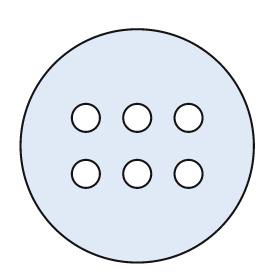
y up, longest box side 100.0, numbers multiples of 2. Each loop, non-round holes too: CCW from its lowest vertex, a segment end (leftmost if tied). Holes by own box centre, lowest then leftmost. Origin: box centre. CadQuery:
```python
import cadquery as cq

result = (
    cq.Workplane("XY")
    .moveTo(0.0, 0.0)
    .circle(50.0)
    .moveTo(-22.0, -12.0)
    .circle(6.0)
    .moveTo(0.0, -12.0)
    .circle(6.0)
    .moveTo(22.0, -12.0)
    .circle(6.0)
    .moveTo(-22.0, 12.0)
    .circle(6.0)
    .moveTo(0.0, 12.0)
    .circle(6.0)
    .moveTo(22.0, 12.0)
    .circle(6.0)
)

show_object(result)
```